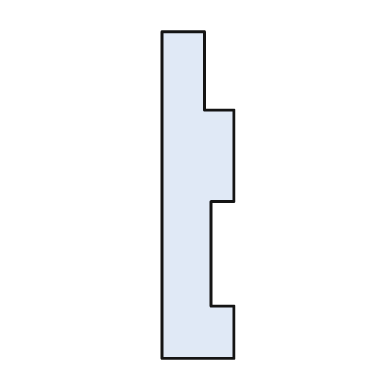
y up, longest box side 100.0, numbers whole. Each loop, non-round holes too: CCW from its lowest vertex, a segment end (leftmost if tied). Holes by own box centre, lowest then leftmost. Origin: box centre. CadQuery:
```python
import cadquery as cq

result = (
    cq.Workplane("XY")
    .moveTo(-11.0, -50.0)
    .lineTo(11.0, -50.0)
    .lineTo(11.0, -34.0)
    .lineTo(4.0, -34.0)
    .lineTo(4.0, -2.0)
    .lineTo(11.0, -2.0)
    .lineTo(11.0, 26.0)
    .lineTo(2.0, 26.0)
    .lineTo(2.0, 50.0)
    .lineTo(-11.0, 50.0)
    .close()
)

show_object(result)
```